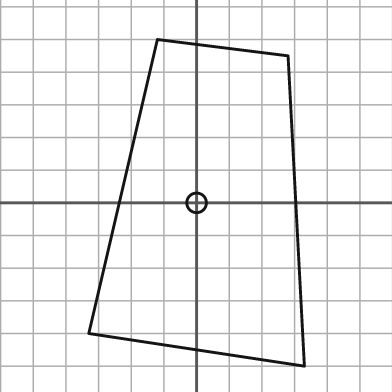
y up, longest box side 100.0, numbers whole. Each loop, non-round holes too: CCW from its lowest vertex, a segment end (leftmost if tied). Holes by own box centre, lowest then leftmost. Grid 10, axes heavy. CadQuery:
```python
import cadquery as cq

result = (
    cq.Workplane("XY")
    .moveTo(33.0, -50.0)
    .lineTo(28.0, 45.0)
    .lineTo(-12.0, 50.0)
    .lineTo(-33.0, -40.0)
    .close()
    .moveTo(0.0, 0.0)
    .circle(3.0)
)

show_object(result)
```